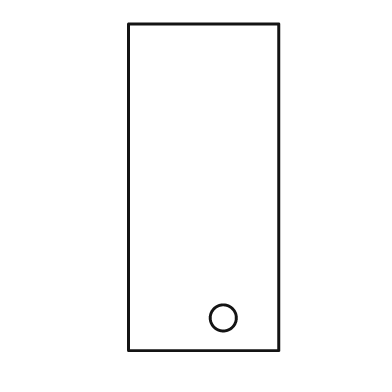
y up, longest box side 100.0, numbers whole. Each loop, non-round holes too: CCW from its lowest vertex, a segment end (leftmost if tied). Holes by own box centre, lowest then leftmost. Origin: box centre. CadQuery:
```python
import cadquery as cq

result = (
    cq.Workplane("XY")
    .moveTo(-23.0, -50.0)
    .lineTo(23.0, -50.0)
    .lineTo(23.0, 50.0)
    .lineTo(-23.0, 50.0)
    .close()
    .moveTo(6.0, -40.0)
    .circle(4.0)
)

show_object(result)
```